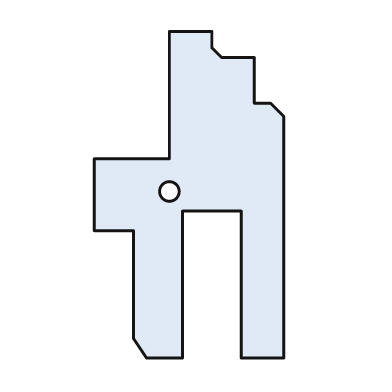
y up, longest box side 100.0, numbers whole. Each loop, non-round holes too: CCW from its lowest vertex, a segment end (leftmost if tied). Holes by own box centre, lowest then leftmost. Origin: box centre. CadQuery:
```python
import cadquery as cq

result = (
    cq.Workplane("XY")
    .moveTo(-13.0, -50.0)
    .lineTo(-2.0, -50.0)
    .lineTo(-2.0, -5.0)
    .lineTo(16.0, -5.0)
    .lineTo(16.0, -50.0)
    .lineTo(29.0, -50.0)
    .lineTo(29.0, 24.0)
    .lineTo(25.0, 28.0)
    .lineTo(20.0, 28.0)
    .lineTo(20.0, 42.0)
    .lineTo(10.0, 42.0)
    .lineTo(7.0, 45.0)
    .lineTo(7.0, 50.0)
    .lineTo(-6.0, 50.0)
    .lineTo(-6.0, 11.0)
    .lineTo(-29.0, 11.0)
    .lineTo(-29.0, -11.0)
    .lineTo(-17.0, -11.0)
    .lineTo(-17.0, -44.0)
    .close()
    .moveTo(-6.0, 1.0)
    .circle(3.0)
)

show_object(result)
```